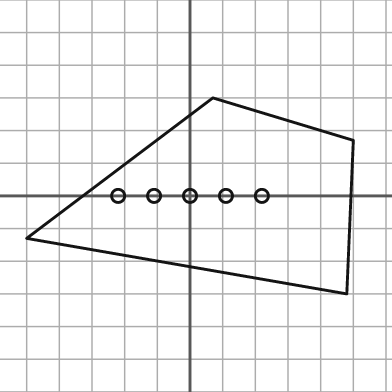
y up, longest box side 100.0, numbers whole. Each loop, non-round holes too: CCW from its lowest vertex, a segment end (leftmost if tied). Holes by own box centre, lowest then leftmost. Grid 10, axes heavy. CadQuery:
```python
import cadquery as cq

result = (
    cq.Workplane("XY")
    .moveTo(48.0, -30.0)
    .lineTo(50.0, 17.0)
    .lineTo(7.0, 30.0)
    .lineTo(-50.0, -13.0)
    .close()
    .moveTo(-22.0, 0.0)
    .circle(2.0)
    .moveTo(-11.0, 0.0)
    .circle(2.0)
    .moveTo(0.0, 0.0)
    .circle(2.0)
    .moveTo(11.0, 0.0)
    .circle(2.0)
    .moveTo(22.0, 0.0)
    .circle(2.0)
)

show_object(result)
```